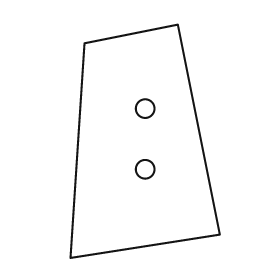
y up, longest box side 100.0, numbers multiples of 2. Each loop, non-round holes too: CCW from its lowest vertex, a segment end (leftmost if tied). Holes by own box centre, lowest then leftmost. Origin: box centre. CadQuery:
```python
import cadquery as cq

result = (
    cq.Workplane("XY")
    .moveTo(-32.0, -50.0)
    .lineTo(32.0, -40.0)
    .lineTo(14.0, 50.0)
    .lineTo(-26.0, 42.0)
    .close()
    .moveTo(0.0, -12.0)
    .circle(4.0)
    .moveTo(0.0, 14.0)
    .circle(4.0)
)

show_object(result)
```